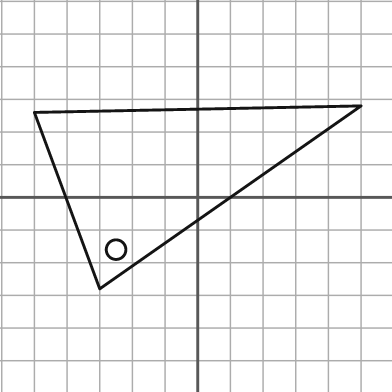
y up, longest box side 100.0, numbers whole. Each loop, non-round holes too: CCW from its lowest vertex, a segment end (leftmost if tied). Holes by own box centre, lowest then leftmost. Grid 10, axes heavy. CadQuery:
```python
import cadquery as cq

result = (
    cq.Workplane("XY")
    .moveTo(-30.0, -28.0)
    .lineTo(50.0, 28.0)
    .lineTo(-50.0, 26.0)
    .close()
    .moveTo(-25.0, -16.0)
    .circle(3.0)
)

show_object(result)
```